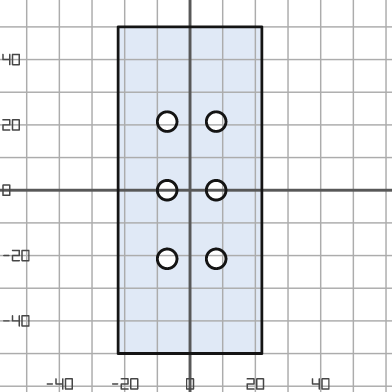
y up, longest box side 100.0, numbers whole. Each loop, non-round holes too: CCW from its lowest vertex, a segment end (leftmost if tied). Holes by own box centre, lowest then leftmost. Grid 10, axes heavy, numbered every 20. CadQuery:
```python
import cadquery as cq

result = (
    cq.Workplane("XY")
    .moveTo(-22.0, -50.0)
    .lineTo(22.0, -50.0)
    .lineTo(22.0, 50.0)
    .lineTo(-22.0, 50.0)
    .close()
    .moveTo(-7.0, -21.0)
    .circle(3.0)
    .moveTo(8.0, -21.0)
    .circle(3.0)
    .moveTo(-7.0, 0.0)
    .circle(3.0)
    .moveTo(8.0, 0.0)
    .circle(3.0)
    .moveTo(-7.0, 21.0)
    .circle(3.0)
    .moveTo(8.0, 21.0)
    .circle(3.0)
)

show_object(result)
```